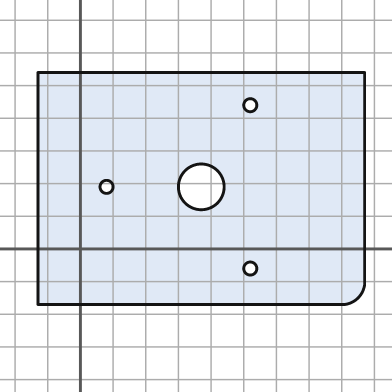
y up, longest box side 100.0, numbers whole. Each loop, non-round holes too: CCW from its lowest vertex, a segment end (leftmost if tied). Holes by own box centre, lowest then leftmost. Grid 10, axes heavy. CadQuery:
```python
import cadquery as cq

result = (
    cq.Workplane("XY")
    .moveTo(-13.0, -17.0)
    .lineTo(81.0, -17.0)
    .threePointArc((85.0, -15.0), (87.0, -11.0))
    .lineTo(87.0, 54.0)
    .lineTo(-13.0, 54.0)
    .close()
    .moveTo(52.0, -6.0)
    .circle(2.0)
    .moveTo(8.0, 19.0)
    .circle(2.0)
    .moveTo(37.0, 19.0)
    .circle(7.0)
    .moveTo(52.0, 44.0)
    .circle(2.0)
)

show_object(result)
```